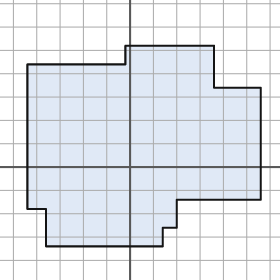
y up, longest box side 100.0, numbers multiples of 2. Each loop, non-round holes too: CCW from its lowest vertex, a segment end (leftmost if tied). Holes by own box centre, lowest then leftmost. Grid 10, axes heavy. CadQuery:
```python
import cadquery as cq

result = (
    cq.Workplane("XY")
    .moveTo(-36.0, -34.0)
    .lineTo(14.0, -34.0)
    .lineTo(14.0, -26.0)
    .lineTo(20.0, -26.0)
    .lineTo(20.0, -14.0)
    .lineTo(56.0, -14.0)
    .lineTo(56.0, 34.0)
    .lineTo(36.0, 34.0)
    .lineTo(36.0, 52.0)
    .lineTo(-2.0, 52.0)
    .lineTo(-2.0, 44.0)
    .lineTo(-44.0, 44.0)
    .lineTo(-44.0, -18.0)
    .lineTo(-36.0, -18.0)
    .close()
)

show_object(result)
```